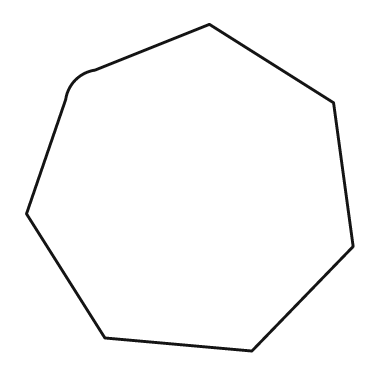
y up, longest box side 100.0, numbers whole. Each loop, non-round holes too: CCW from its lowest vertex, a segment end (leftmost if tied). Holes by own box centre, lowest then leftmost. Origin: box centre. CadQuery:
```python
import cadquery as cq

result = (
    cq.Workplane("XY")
    .moveTo(19.0, -50.0)
    .lineTo(50.0, -18.0)
    .lineTo(44.0, 26.0)
    .lineTo(6.0, 50.0)
    .lineTo(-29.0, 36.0)
    .threePointArc((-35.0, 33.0), (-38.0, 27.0))
    .lineTo(-50.0, -8.0)
    .lineTo(-26.0, -46.0)
    .close()
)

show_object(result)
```